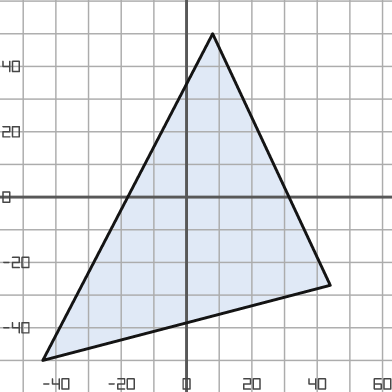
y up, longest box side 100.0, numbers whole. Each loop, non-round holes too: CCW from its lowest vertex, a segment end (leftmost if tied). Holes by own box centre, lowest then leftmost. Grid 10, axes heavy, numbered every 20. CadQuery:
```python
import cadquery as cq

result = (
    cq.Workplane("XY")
    .moveTo(-44.0, -50.0)
    .lineTo(44.0, -27.0)
    .lineTo(8.0, 50.0)
    .close()
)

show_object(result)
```